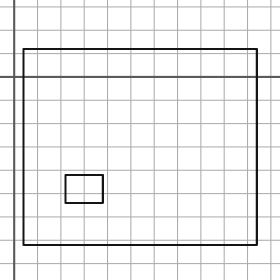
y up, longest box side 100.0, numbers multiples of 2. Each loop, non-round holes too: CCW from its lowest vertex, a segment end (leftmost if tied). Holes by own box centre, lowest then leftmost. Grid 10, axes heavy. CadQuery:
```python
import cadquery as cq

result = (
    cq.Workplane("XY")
    .moveTo(4.0, -72.0)
    .lineTo(104.0, -72.0)
    .lineTo(104.0, 12.0)
    .lineTo(4.0, 12.0)
    .close()
    .moveTo(22.0, -54.0)
    .lineTo(38.0, -54.0)
    .lineTo(38.0, -42.0)
    .lineTo(22.0, -42.0)
    .close()
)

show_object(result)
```